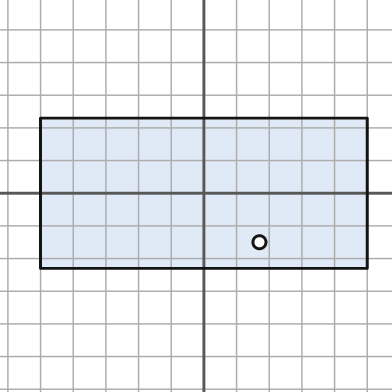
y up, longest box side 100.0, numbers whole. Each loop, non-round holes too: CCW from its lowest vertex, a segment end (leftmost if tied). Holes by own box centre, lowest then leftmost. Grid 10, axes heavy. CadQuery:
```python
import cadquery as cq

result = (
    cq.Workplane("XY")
    .moveTo(-50.0, -23.0)
    .lineTo(50.0, -23.0)
    .lineTo(50.0, 23.0)
    .lineTo(-50.0, 23.0)
    .close()
    .moveTo(17.0, -15.0)
    .circle(2.0)
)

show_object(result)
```